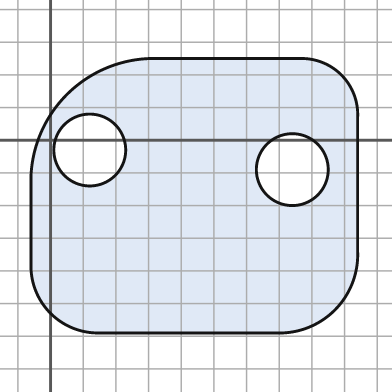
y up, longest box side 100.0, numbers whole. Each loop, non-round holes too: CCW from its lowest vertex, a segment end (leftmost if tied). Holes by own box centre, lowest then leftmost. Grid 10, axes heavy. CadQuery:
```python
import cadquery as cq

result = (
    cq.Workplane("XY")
    .moveTo(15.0, -59.0)
    .lineTo(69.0, -59.0)
    .threePointArc((87.0, -52.0), (94.0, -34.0))
    .lineTo(94.0, 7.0)
    .threePointArc((89.0, 20.0), (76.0, 25.0))
    .lineTo(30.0, 25.0)
    .threePointArc((5.0, 14.0), (-6.0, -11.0))
    .lineTo(-6.0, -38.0)
    .threePointArc((0.0, -53.0), (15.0, -59.0))
    .close()
    .moveTo(74.0, -9.0)
    .circle(11.0)
    .moveTo(12.0, -3.0)
    .circle(11.0)
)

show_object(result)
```